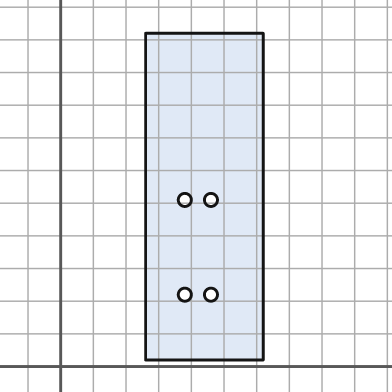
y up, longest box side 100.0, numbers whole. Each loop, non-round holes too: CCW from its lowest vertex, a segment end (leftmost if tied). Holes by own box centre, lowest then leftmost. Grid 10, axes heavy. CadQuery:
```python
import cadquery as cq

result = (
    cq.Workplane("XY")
    .moveTo(26.0, 2.0)
    .lineTo(62.0, 2.0)
    .lineTo(62.0, 102.0)
    .lineTo(26.0, 102.0)
    .close()
    .moveTo(38.0, 22.0)
    .circle(2.0)
    .moveTo(46.0, 22.0)
    .circle(2.0)
    .moveTo(38.0, 51.0)
    .circle(2.0)
    .moveTo(46.0, 51.0)
    .circle(2.0)
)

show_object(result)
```